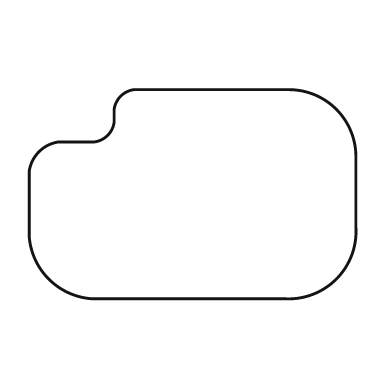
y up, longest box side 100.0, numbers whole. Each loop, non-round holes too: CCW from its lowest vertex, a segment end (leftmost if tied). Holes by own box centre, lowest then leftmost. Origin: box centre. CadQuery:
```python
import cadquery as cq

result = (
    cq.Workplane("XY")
    .moveTo(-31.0, -32.0)
    .lineTo(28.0, -32.0)
    .threePointArc((44.0, -26.0), (50.0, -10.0))
    .lineTo(50.0, 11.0)
    .threePointArc((44.0, 26.0), (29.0, 32.0))
    .lineTo(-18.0, 32.0)
    .threePointArc((-22.0, 30.0), (-24.0, 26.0))
    .lineTo(-24.0, 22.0)
    .threePointArc((-26.0, 18.0), (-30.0, 16.0))
    .lineTo(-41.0, 16.0)
    .threePointArc((-47.0, 13.0), (-50.0, 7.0))
    .lineTo(-50.0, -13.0)
    .threePointArc((-44.0, -26.0), (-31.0, -32.0))
    .close()
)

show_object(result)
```